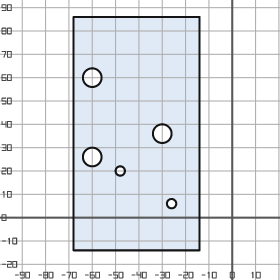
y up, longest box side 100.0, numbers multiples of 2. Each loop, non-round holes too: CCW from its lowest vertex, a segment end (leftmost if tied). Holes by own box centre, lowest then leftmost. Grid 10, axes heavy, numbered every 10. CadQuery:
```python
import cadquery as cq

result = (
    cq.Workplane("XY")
    .moveTo(-68.0, -14.0)
    .lineTo(-14.0, -14.0)
    .lineTo(-14.0, 86.0)
    .lineTo(-68.0, 86.0)
    .close()
    .moveTo(-26.0, 6.0)
    .circle(2.0)
    .moveTo(-48.0, 20.0)
    .circle(2.0)
    .moveTo(-60.0, 26.0)
    .circle(4.0)
    .moveTo(-30.0, 36.0)
    .circle(4.0)
    .moveTo(-60.0, 60.0)
    .circle(4.0)
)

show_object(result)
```